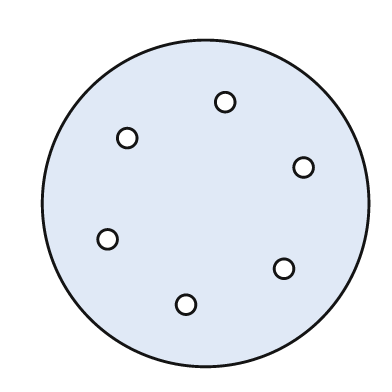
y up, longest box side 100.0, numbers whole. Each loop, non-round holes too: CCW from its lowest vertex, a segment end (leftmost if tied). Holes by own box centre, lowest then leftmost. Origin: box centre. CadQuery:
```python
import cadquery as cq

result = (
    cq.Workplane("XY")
    .moveTo(0.0, 0.0)
    .circle(50.0)
    .moveTo(-6.0, -31.0)
    .circle(3.0)
    .moveTo(24.0, -20.0)
    .circle(3.0)
    .moveTo(-30.0, -11.0)
    .circle(3.0)
    .moveTo(30.0, 11.0)
    .circle(3.0)
    .moveTo(-24.0, 20.0)
    .circle(3.0)
    .moveTo(6.0, 31.0)
    .circle(3.0)
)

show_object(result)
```